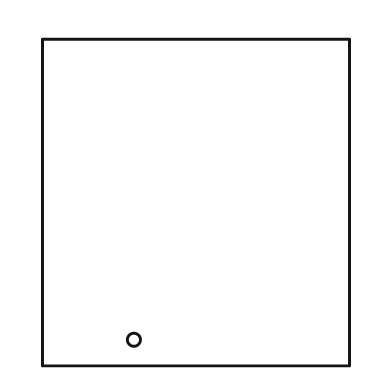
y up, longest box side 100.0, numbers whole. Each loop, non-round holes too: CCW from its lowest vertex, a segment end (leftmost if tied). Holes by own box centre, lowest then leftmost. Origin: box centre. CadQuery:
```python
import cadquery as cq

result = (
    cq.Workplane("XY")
    .moveTo(-47.0, -50.0)
    .lineTo(47.0, -50.0)
    .lineTo(47.0, 50.0)
    .lineTo(-47.0, 50.0)
    .close()
    .moveTo(-19.0, -42.0)
    .circle(2.0)
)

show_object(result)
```